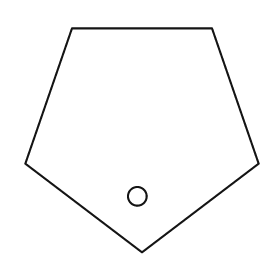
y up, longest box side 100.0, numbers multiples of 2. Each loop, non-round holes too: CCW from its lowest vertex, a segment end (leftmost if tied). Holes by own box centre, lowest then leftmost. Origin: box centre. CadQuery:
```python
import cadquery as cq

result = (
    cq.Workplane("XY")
    .moveTo(0.0, -48.0)
    .lineTo(50.0, -10.0)
    .lineTo(30.0, 48.0)
    .lineTo(-30.0, 48.0)
    .lineTo(-50.0, -10.0)
    .close()
    .moveTo(-2.0, -24.0)
    .circle(4.0)
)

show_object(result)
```